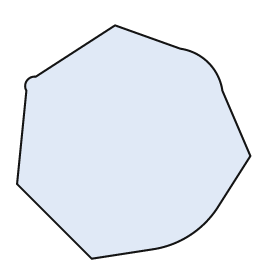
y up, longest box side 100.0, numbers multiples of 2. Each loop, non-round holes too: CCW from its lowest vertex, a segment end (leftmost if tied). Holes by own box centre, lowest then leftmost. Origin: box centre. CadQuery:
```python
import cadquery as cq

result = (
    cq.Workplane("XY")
    .moveTo(-18.0, -50.0)
    .lineTo(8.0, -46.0)
    .threePointArc((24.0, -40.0), (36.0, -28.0))
    .lineTo(50.0, -6.0)
    .lineTo(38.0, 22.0)
    .threePointArc((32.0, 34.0), (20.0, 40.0))
    .lineTo(-8.0, 50.0)
    .lineTo(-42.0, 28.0)
    .threePointArc((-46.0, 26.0), (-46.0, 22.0))
    .lineTo(-50.0, -18.0)
    .close()
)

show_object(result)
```